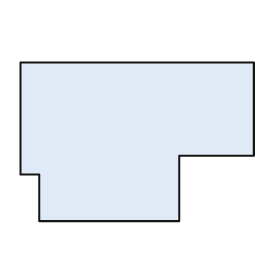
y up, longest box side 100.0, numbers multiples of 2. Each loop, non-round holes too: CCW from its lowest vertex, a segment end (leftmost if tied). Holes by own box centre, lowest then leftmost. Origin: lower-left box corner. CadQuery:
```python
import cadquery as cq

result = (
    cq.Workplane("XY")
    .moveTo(8.0, 0.0)
    .lineTo(68.0, 0.0)
    .lineTo(68.0, 28.0)
    .lineTo(100.0, 28.0)
    .lineTo(100.0, 68.0)
    .lineTo(0.0, 68.0)
    .lineTo(0.0, 20.0)
    .lineTo(8.0, 20.0)
    .close()
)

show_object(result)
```